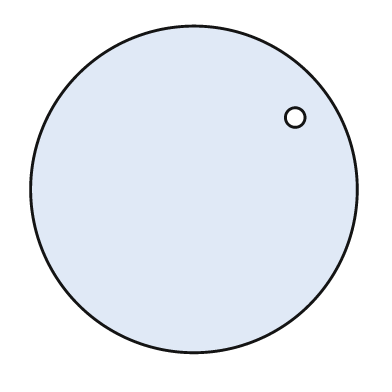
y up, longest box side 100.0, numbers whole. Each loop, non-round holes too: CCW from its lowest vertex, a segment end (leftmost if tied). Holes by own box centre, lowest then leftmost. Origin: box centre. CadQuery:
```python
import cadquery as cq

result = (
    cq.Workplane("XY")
    .moveTo(0.0, 0.0)
    .circle(50.0)
    .moveTo(31.0, 22.0)
    .circle(3.0)
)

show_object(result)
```